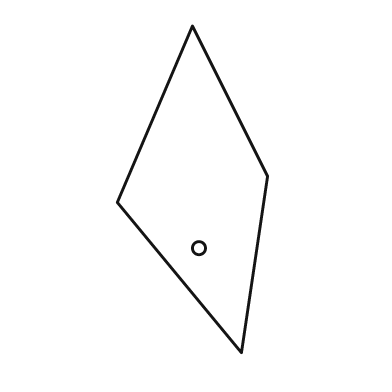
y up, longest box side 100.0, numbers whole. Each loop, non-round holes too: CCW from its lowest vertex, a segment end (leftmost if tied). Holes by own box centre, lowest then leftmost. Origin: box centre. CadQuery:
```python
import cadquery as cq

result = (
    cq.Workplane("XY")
    .moveTo(15.0, -50.0)
    .lineTo(23.0, 4.0)
    .lineTo(0.0, 50.0)
    .lineTo(-23.0, -4.0)
    .close()
    .moveTo(2.0, -18.0)
    .circle(2.0)
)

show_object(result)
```